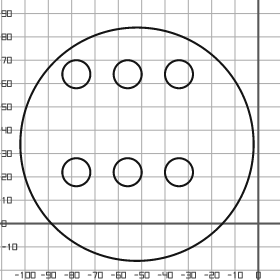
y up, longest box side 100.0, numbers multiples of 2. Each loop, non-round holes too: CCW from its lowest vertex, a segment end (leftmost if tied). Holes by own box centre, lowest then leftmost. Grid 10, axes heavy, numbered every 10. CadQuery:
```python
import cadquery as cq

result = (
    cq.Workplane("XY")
    .moveTo(-52.0, 34.0)
    .circle(50.0)
    .moveTo(-78.0, 22.0)
    .circle(6.0)
    .moveTo(-56.0, 22.0)
    .circle(6.0)
    .moveTo(-34.0, 22.0)
    .circle(6.0)
    .moveTo(-78.0, 64.0)
    .circle(6.0)
    .moveTo(-56.0, 64.0)
    .circle(6.0)
    .moveTo(-34.0, 64.0)
    .circle(6.0)
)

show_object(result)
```